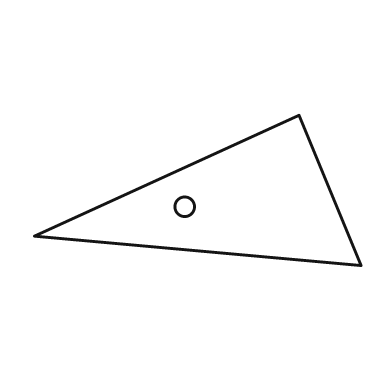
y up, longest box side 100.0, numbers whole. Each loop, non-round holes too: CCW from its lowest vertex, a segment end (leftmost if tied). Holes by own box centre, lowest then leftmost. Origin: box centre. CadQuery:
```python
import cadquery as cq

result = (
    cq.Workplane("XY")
    .moveTo(50.0, -23.0)
    .lineTo(31.0, 23.0)
    .lineTo(-50.0, -14.0)
    .close()
    .moveTo(-4.0, -5.0)
    .circle(3.0)
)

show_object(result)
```